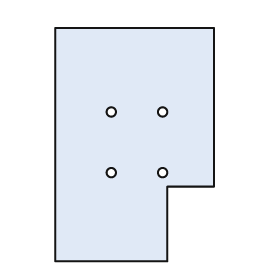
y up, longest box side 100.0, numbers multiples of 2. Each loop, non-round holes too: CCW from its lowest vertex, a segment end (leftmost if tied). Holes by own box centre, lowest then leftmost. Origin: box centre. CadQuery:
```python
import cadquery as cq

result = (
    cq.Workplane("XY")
    .moveTo(-34.0, -50.0)
    .lineTo(14.0, -50.0)
    .lineTo(14.0, -18.0)
    .lineTo(34.0, -18.0)
    .lineTo(34.0, 50.0)
    .lineTo(-34.0, 50.0)
    .close()
    .moveTo(-10.0, -12.0)
    .circle(2.0)
    .moveTo(12.0, -12.0)
    .circle(2.0)
    .moveTo(-10.0, 14.0)
    .circle(2.0)
    .moveTo(12.0, 14.0)
    .circle(2.0)
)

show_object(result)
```